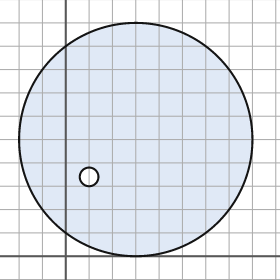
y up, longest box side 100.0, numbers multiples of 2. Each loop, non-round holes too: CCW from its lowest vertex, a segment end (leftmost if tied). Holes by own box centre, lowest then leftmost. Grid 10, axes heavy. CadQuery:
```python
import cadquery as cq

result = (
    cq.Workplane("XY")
    .moveTo(30.0, 50.0)
    .circle(50.0)
    .moveTo(10.0, 34.0)
    .circle(4.0)
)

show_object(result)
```